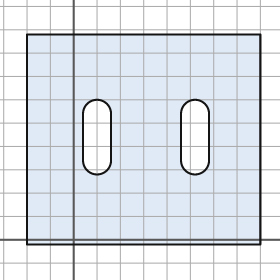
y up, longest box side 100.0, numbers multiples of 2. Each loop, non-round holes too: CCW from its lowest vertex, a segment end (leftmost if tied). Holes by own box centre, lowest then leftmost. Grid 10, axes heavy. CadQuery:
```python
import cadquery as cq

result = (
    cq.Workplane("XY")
    .moveTo(-20.0, -2.0)
    .lineTo(80.0, -2.0)
    .lineTo(80.0, 88.0)
    .lineTo(-20.0, 88.0)
    .close()
    .moveTo(4.0, 34.0)
    .threePointArc((10.0, 28.0), (16.0, 34.0))
    .lineTo(16.0, 54.0)
    .threePointArc((10.0, 60.0), (4.0, 54.0))
    .close()
    .moveTo(46.0, 34.0)
    .threePointArc((52.0, 28.0), (58.0, 34.0))
    .lineTo(58.0, 54.0)
    .threePointArc((52.0, 60.0), (46.0, 54.0))
    .close()
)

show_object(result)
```